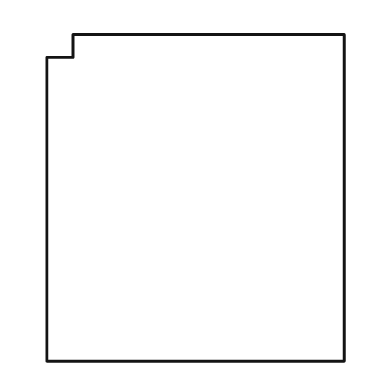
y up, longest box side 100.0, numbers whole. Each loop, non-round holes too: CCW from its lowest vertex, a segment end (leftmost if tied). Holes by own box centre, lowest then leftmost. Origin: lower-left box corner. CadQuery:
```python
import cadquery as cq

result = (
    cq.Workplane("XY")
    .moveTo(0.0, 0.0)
    .lineTo(91.0, 0.0)
    .lineTo(91.0, 100.0)
    .lineTo(8.0, 100.0)
    .lineTo(8.0, 93.0)
    .lineTo(0.0, 93.0)
    .close()
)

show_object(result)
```